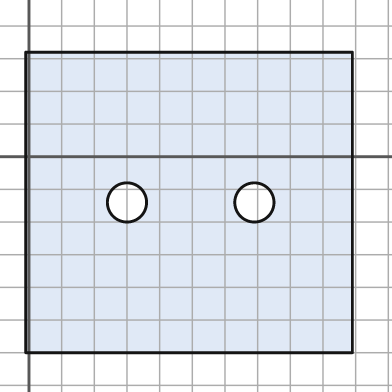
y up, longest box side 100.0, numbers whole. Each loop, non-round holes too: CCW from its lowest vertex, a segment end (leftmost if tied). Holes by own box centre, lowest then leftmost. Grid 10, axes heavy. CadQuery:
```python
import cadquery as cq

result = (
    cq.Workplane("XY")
    .moveTo(-1.0, -60.0)
    .lineTo(99.0, -60.0)
    .lineTo(99.0, 32.0)
    .lineTo(-1.0, 32.0)
    .close()
    .moveTo(30.0, -14.0)
    .circle(6.0)
    .moveTo(69.0, -14.0)
    .circle(6.0)
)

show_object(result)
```